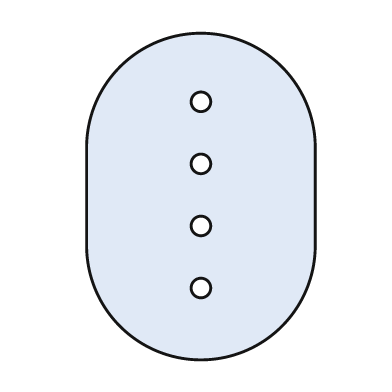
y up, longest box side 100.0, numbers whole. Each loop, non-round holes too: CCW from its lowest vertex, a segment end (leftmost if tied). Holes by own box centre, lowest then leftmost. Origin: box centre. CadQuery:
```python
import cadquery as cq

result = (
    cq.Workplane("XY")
    .moveTo(-35.0, -15.0)
    .threePointArc((0.0, -50.0), (35.0, -15.0))
    .lineTo(35.0, 15.0)
    .threePointArc((0.0, 50.0), (-35.0, 15.0))
    .close()
    .moveTo(0.0, -28.0)
    .circle(3.0)
    .moveTo(0.0, -9.0)
    .circle(3.0)
    .moveTo(0.0, 10.0)
    .circle(3.0)
    .moveTo(0.0, 29.0)
    .circle(3.0)
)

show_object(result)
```